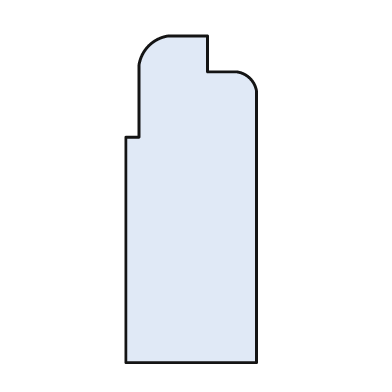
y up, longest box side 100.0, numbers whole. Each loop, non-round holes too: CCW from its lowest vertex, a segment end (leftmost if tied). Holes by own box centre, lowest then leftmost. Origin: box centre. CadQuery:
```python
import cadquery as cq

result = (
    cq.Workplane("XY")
    .moveTo(-20.0, -50.0)
    .lineTo(20.0, -50.0)
    .lineTo(20.0, 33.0)
    .threePointArc((18.0, 37.0), (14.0, 39.0))
    .lineTo(5.0, 39.0)
    .lineTo(5.0, 50.0)
    .lineTo(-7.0, 50.0)
    .threePointArc((-13.0, 47.0), (-16.0, 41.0))
    .lineTo(-16.0, 19.0)
    .lineTo(-20.0, 19.0)
    .close()
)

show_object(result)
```